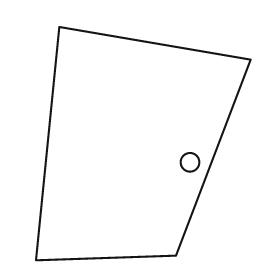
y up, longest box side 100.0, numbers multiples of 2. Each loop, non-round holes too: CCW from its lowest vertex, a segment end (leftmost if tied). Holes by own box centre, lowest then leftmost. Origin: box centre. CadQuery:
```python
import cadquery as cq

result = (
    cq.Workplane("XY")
    .moveTo(-46.0, -50.0)
    .lineTo(14.0, -48.0)
    .lineTo(46.0, 36.0)
    .lineTo(-36.0, 50.0)
    .close()
    .moveTo(20.0, -8.0)
    .circle(4.0)
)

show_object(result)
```